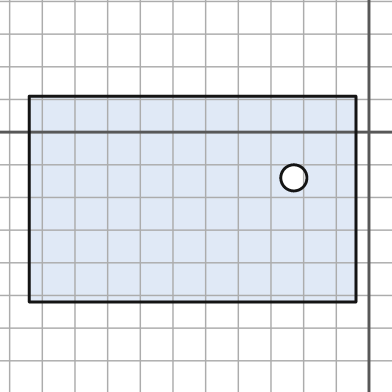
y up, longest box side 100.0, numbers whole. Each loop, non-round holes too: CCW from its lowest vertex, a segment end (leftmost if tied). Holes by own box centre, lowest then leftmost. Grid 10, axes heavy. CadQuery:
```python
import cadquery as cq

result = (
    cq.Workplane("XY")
    .moveTo(-104.0, -52.0)
    .lineTo(-4.0, -52.0)
    .lineTo(-4.0, 11.0)
    .lineTo(-104.0, 11.0)
    .close()
    .moveTo(-23.0, -14.0)
    .circle(4.0)
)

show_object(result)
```